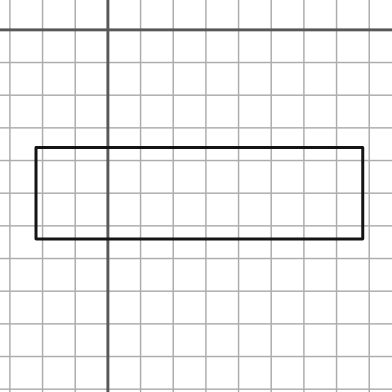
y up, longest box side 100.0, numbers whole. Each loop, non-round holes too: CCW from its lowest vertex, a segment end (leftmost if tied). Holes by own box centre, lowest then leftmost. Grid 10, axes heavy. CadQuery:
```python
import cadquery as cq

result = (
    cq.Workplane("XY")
    .moveTo(-22.0, -64.0)
    .lineTo(78.0, -64.0)
    .lineTo(78.0, -36.0)
    .lineTo(-22.0, -36.0)
    .close()
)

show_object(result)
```